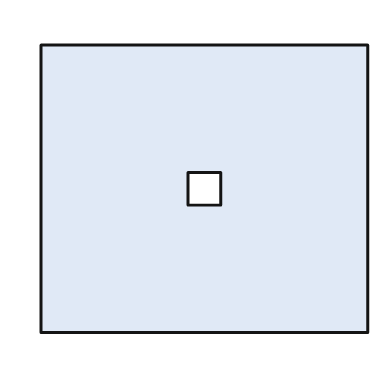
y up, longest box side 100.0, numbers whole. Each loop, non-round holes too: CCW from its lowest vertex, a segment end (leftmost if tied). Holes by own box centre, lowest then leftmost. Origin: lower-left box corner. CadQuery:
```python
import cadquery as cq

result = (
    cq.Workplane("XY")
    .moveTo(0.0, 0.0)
    .lineTo(100.0, 0.0)
    .lineTo(100.0, 88.0)
    .lineTo(0.0, 88.0)
    .close()
    .moveTo(45.0, 39.0)
    .lineTo(55.0, 39.0)
    .lineTo(55.0, 49.0)
    .lineTo(45.0, 49.0)
    .close()
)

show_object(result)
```